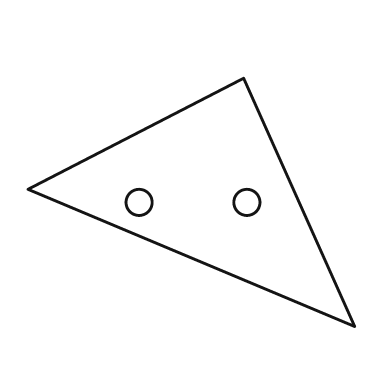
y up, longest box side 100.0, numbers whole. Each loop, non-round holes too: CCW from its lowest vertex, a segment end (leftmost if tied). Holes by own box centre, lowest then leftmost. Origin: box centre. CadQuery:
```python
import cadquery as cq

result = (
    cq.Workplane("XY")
    .moveTo(50.0, -38.0)
    .lineTo(16.0, 38.0)
    .lineTo(-50.0, 4.0)
    .close()
    .moveTo(-16.0, 0.0)
    .circle(4.0)
    .moveTo(17.0, 0.0)
    .circle(4.0)
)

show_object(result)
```